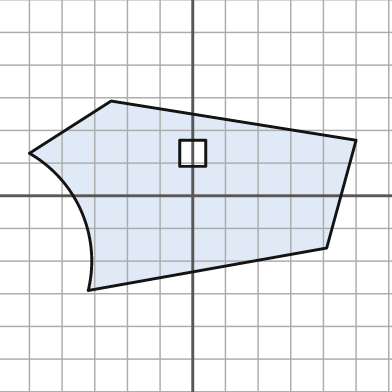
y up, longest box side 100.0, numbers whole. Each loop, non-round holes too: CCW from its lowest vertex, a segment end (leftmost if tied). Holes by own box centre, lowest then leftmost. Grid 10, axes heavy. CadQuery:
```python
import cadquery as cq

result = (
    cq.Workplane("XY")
    .moveTo(-32.0, -29.0)
    .lineTo(41.0, -16.0)
    .lineTo(50.0, 17.0)
    .lineTo(-25.0, 29.0)
    .lineTo(-50.0, 13.0)
    .threePointArc((-34.0, -5.0), (-32.0, -29.0))
    .close()
    .moveTo(-4.0, 9.0)
    .lineTo(4.0, 9.0)
    .lineTo(4.0, 17.0)
    .lineTo(-4.0, 17.0)
    .close()
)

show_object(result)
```